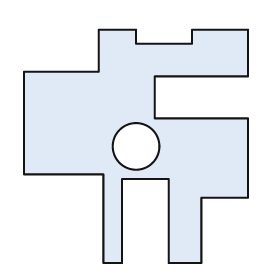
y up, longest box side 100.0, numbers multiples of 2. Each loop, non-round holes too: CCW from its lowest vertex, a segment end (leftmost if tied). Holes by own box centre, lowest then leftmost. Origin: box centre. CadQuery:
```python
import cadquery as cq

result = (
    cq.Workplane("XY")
    .moveTo(-14.0, -50.0)
    .lineTo(-6.0, -50.0)
    .lineTo(-6.0, -14.0)
    .lineTo(14.0, -14.0)
    .lineTo(14.0, -50.0)
    .lineTo(28.0, -50.0)
    .lineTo(28.0, -22.0)
    .lineTo(48.0, -22.0)
    .lineTo(48.0, 12.0)
    .lineTo(8.0, 12.0)
    .lineTo(8.0, 30.0)
    .lineTo(48.0, 30.0)
    .lineTo(48.0, 50.0)
    .lineTo(24.0, 50.0)
    .lineTo(24.0, 44.0)
    .lineTo(0.0, 44.0)
    .lineTo(0.0, 50.0)
    .lineTo(-16.0, 50.0)
    .lineTo(-16.0, 32.0)
    .lineTo(-48.0, 32.0)
    .lineTo(-48.0, -12.0)
    .lineTo(-14.0, -12.0)
    .close()
    .moveTo(0.0, 0.0)
    .circle(10.0)
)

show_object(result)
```